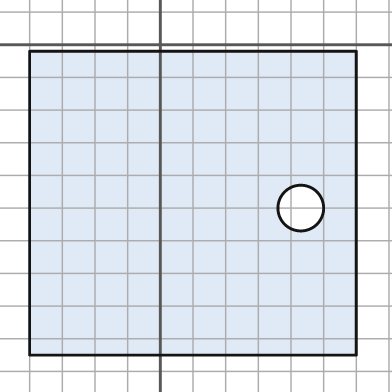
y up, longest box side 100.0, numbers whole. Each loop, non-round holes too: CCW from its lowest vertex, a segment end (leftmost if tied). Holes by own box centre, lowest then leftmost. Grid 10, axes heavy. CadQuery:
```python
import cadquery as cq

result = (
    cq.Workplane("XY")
    .moveTo(-40.0, -95.0)
    .lineTo(60.0, -95.0)
    .lineTo(60.0, -2.0)
    .lineTo(-40.0, -2.0)
    .close()
    .moveTo(43.0, -50.0)
    .circle(7.0)
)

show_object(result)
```